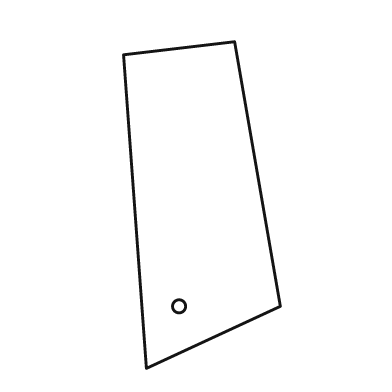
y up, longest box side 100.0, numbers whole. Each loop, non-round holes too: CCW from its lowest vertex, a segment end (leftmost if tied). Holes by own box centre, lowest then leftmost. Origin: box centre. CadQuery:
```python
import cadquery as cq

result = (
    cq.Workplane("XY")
    .moveTo(-17.0, -50.0)
    .lineTo(24.0, -31.0)
    .lineTo(10.0, 50.0)
    .lineTo(-24.0, 46.0)
    .close()
    .moveTo(-7.0, -31.0)
    .circle(2.0)
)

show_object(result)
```